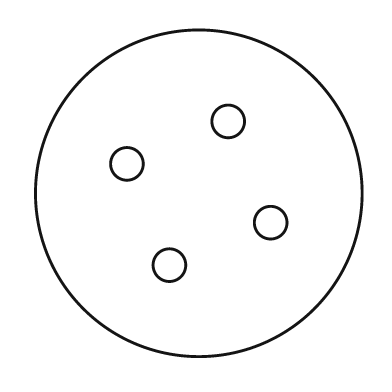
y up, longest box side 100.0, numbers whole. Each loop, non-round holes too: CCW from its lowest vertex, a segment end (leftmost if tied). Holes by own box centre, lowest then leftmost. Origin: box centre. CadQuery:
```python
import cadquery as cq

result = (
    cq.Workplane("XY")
    .moveTo(0.0, 0.0)
    .circle(50.0)
    .moveTo(-9.0, -22.0)
    .circle(5.0)
    .moveTo(22.0, -9.0)
    .circle(5.0)
    .moveTo(-22.0, 9.0)
    .circle(5.0)
    .moveTo(9.0, 22.0)
    .circle(5.0)
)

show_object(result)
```